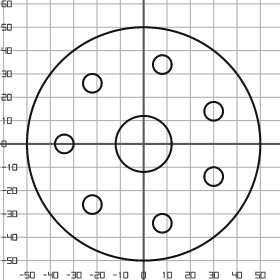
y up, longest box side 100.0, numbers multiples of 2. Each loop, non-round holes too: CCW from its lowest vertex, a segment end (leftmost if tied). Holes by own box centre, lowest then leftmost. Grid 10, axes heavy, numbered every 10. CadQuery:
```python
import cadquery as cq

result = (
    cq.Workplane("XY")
    .moveTo(0.0, 0.0)
    .circle(50.0)
    .moveTo(8.0, -34.0)
    .circle(4.0)
    .moveTo(-22.0, -26.0)
    .circle(4.0)
    .moveTo(30.0, -14.0)
    .circle(4.0)
    .moveTo(-34.0, 0.0)
    .circle(4.0)
    .moveTo(0.0, 0.0)
    .circle(12.0)
    .moveTo(30.0, 14.0)
    .circle(4.0)
    .moveTo(-22.0, 26.0)
    .circle(4.0)
    .moveTo(8.0, 34.0)
    .circle(4.0)
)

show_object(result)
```